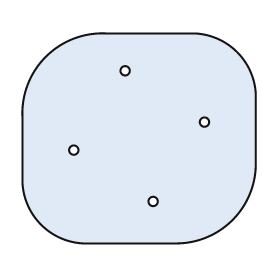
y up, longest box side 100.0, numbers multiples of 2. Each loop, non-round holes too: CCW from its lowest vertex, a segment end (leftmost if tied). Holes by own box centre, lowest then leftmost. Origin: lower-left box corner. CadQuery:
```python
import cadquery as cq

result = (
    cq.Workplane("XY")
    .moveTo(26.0, 0.0)
    .lineTo(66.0, 0.0)
    .threePointArc((90.0, 10.0), (100.0, 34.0))
    .lineTo(100.0, 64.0)
    .threePointArc((92.0, 82.0), (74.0, 90.0))
    .lineTo(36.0, 90.0)
    .threePointArc((10.0, 80.0), (0.0, 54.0))
    .lineTo(0.0, 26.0)
    .threePointArc((8.0, 8.0), (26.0, 0.0))
    .close()
    .moveTo(56.0, 18.0)
    .circle(2.0)
    .moveTo(22.0, 40.0)
    .circle(2.0)
    .moveTo(78.0, 52.0)
    .circle(2.0)
    .moveTo(44.0, 74.0)
    .circle(2.0)
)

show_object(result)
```